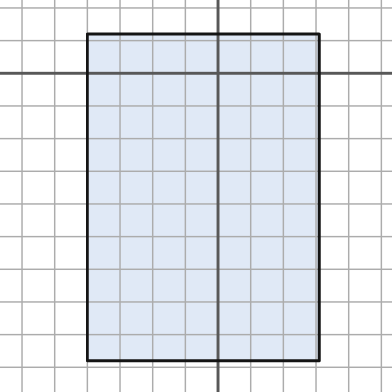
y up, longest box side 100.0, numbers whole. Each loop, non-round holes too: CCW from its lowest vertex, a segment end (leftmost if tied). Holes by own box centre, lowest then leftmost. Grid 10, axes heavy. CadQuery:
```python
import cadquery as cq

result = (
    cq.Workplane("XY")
    .moveTo(-40.0, -88.0)
    .lineTo(31.0, -88.0)
    .lineTo(31.0, 12.0)
    .lineTo(-40.0, 12.0)
    .close()
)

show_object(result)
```